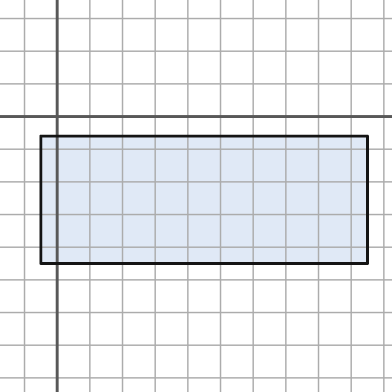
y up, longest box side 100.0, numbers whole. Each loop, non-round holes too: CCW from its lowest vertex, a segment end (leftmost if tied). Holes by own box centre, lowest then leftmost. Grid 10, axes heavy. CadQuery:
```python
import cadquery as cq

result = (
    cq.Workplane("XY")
    .moveTo(-5.0, -45.0)
    .lineTo(95.0, -45.0)
    .lineTo(95.0, -6.0)
    .lineTo(-5.0, -6.0)
    .close()
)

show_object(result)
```